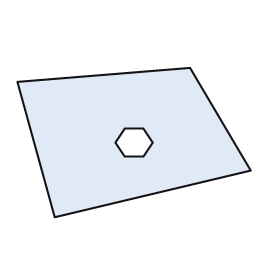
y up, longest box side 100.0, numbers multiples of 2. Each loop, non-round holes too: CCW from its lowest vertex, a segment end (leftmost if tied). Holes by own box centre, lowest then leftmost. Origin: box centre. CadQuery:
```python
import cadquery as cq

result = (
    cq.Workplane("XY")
    .moveTo(-34.0, -32.0)
    .lineTo(50.0, -12.0)
    .lineTo(24.0, 32.0)
    .lineTo(-50.0, 26.0)
    .close()
    .moveTo(-4.0, -6.0)
    .lineTo(4.0, -6.0)
    .lineTo(8.0, 0.0)
    .lineTo(4.0, 6.0)
    .lineTo(-4.0, 6.0)
    .lineTo(-8.0, 0.0)
    .close()
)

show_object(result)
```